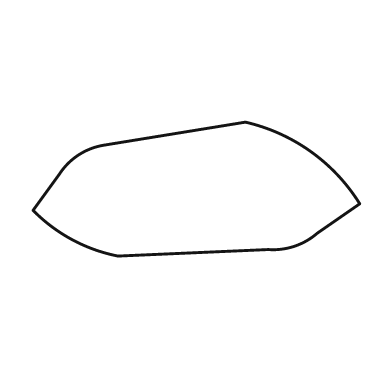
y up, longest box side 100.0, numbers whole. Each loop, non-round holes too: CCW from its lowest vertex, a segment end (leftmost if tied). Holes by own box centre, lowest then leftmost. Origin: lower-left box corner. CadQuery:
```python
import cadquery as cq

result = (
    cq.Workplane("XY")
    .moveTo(26.0, 0.0)
    .lineTo(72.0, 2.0)
    .threePointArc((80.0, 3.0), (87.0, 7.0))
    .lineTo(100.0, 16.0)
    .threePointArc((85.0, 32.0), (65.0, 41.0))
    .lineTo(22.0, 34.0)
    .threePointArc((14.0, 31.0), (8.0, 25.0))
    .lineTo(0.0, 14.0)
    .threePointArc((12.0, 5.0), (26.0, 0.0))
    .close()
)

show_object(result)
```